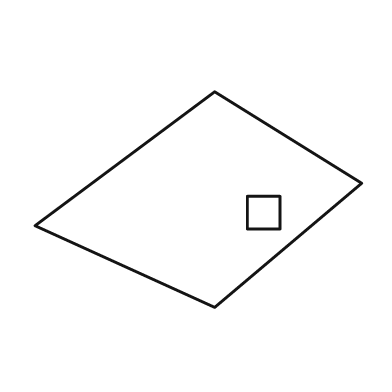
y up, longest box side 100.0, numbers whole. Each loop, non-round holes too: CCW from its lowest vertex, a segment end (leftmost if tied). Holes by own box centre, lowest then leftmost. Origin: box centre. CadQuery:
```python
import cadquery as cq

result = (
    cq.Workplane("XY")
    .moveTo(5.0, -33.0)
    .lineTo(50.0, 5.0)
    .lineTo(5.0, 33.0)
    .lineTo(-50.0, -8.0)
    .close()
    .moveTo(15.0, -9.0)
    .lineTo(25.0, -9.0)
    .lineTo(25.0, 1.0)
    .lineTo(15.0, 1.0)
    .close()
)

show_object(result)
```